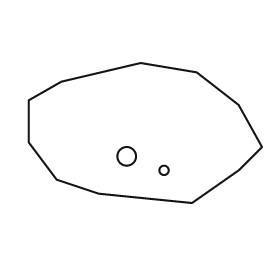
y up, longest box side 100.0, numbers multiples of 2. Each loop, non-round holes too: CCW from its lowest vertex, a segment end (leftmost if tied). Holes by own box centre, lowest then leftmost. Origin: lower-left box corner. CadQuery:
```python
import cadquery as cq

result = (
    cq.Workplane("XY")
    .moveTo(70.0, 0.0)
    .lineTo(90.0, 14.0)
    .lineTo(100.0, 24.0)
    .lineTo(90.0, 42.0)
    .lineTo(72.0, 56.0)
    .lineTo(48.0, 60.0)
    .lineTo(14.0, 52.0)
    .lineTo(0.0, 44.0)
    .lineTo(0.0, 26.0)
    .lineTo(12.0, 10.0)
    .lineTo(30.0, 4.0)
    .close()
    .moveTo(58.0, 14.0)
    .circle(2.0)
    .moveTo(42.0, 20.0)
    .circle(4.0)
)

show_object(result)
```